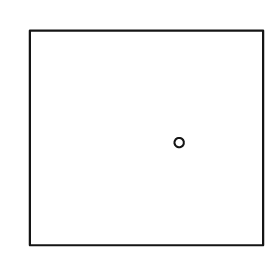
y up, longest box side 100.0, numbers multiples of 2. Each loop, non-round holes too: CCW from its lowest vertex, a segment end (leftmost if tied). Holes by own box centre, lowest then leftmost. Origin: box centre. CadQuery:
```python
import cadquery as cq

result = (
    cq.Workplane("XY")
    .moveTo(-50.0, -46.0)
    .lineTo(50.0, -46.0)
    .lineTo(50.0, 46.0)
    .lineTo(-50.0, 46.0)
    .close()
    .moveTo(14.0, -2.0)
    .circle(2.0)
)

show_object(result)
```